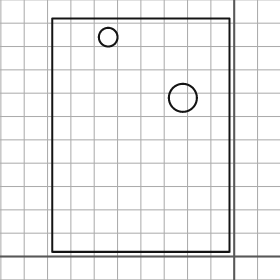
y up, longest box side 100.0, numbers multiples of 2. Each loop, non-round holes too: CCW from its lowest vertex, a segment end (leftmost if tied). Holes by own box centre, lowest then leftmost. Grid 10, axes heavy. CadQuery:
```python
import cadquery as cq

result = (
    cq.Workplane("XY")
    .moveTo(-78.0, 2.0)
    .lineTo(-2.0, 2.0)
    .lineTo(-2.0, 102.0)
    .lineTo(-78.0, 102.0)
    .close()
    .moveTo(-22.0, 68.0)
    .circle(6.0)
    .moveTo(-54.0, 94.0)
    .circle(4.0)
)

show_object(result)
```